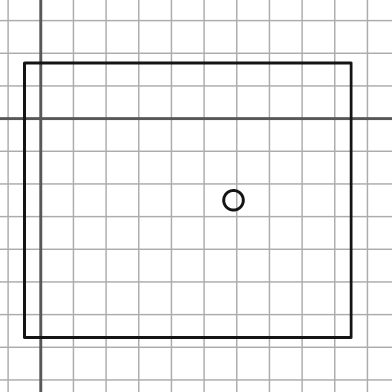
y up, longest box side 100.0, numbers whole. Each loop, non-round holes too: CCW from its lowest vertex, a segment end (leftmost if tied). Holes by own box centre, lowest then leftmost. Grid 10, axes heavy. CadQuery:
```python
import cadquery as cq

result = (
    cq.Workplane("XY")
    .moveTo(-5.0, -67.0)
    .lineTo(95.0, -67.0)
    .lineTo(95.0, 17.0)
    .lineTo(-5.0, 17.0)
    .close()
    .moveTo(59.0, -25.0)
    .circle(3.0)
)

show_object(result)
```